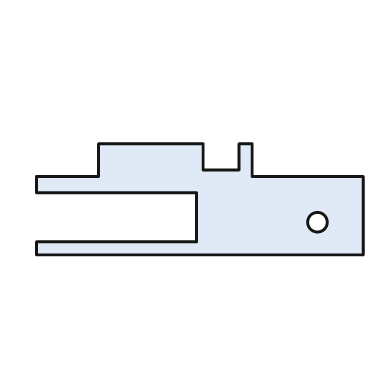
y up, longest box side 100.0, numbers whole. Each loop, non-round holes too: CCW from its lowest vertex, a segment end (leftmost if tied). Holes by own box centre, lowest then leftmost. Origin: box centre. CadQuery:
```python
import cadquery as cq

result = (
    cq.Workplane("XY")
    .moveTo(-50.0, -17.0)
    .lineTo(50.0, -17.0)
    .lineTo(50.0, 7.0)
    .lineTo(16.0, 7.0)
    .lineTo(16.0, 17.0)
    .lineTo(12.0, 17.0)
    .lineTo(12.0, 9.0)
    .lineTo(1.0, 9.0)
    .lineTo(1.0, 17.0)
    .lineTo(-31.0, 17.0)
    .lineTo(-31.0, 7.0)
    .lineTo(-50.0, 7.0)
    .lineTo(-50.0, 2.0)
    .lineTo(-1.0, 2.0)
    .lineTo(-1.0, -13.0)
    .lineTo(-50.0, -13.0)
    .close()
    .moveTo(36.0, -7.0)
    .circle(3.0)
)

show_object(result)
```